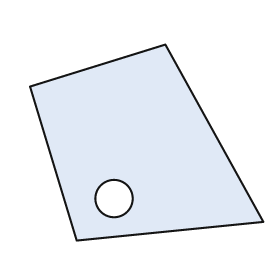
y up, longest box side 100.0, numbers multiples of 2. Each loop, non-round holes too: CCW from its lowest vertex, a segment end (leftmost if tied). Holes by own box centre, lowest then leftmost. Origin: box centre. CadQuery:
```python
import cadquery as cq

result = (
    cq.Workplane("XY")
    .moveTo(-30.0, -42.0)
    .lineTo(50.0, -34.0)
    .lineTo(8.0, 42.0)
    .lineTo(-50.0, 24.0)
    .close()
    .moveTo(-14.0, -24.0)
    .circle(8.0)
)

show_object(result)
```